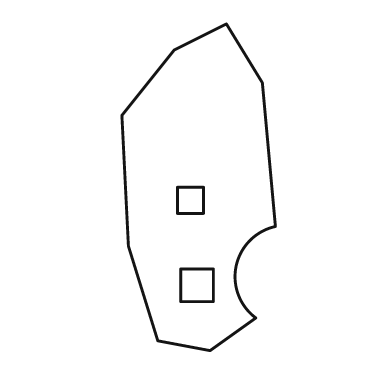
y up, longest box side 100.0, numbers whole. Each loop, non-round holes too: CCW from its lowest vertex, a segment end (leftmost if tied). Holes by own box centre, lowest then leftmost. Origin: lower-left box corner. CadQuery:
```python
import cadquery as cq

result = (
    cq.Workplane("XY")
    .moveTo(27.0, 0.0)
    .lineTo(41.0, 10.0)
    .threePointArc((35.0, 26.0), (47.0, 38.0))
    .lineTo(43.0, 82.0)
    .lineTo(32.0, 100.0)
    .lineTo(16.0, 92.0)
    .lineTo(0.0, 72.0)
    .lineTo(2.0, 32.0)
    .lineTo(11.0, 3.0)
    .close()
    .moveTo(18.0, 15.0)
    .lineTo(28.0, 15.0)
    .lineTo(28.0, 25.0)
    .lineTo(18.0, 25.0)
    .close()
    .moveTo(17.0, 42.0)
    .lineTo(25.0, 42.0)
    .lineTo(25.0, 50.0)
    .lineTo(17.0, 50.0)
    .close()
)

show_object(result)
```